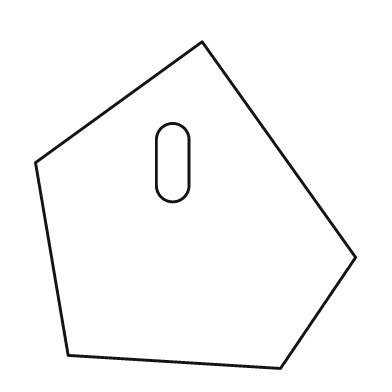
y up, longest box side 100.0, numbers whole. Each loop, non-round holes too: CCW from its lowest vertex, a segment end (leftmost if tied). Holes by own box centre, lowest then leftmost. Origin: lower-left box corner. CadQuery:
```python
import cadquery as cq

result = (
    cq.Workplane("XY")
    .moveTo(75.0, 0.0)
    .lineTo(98.0, 34.0)
    .lineTo(51.0, 100.0)
    .lineTo(0.0, 63.0)
    .lineTo(10.0, 4.0)
    .close()
    .moveTo(37.0, 56.0)
    .threePointArc((42.0, 51.0), (47.0, 56.0))
    .lineTo(47.0, 70.0)
    .threePointArc((42.0, 75.0), (37.0, 70.0))
    .close()
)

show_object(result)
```